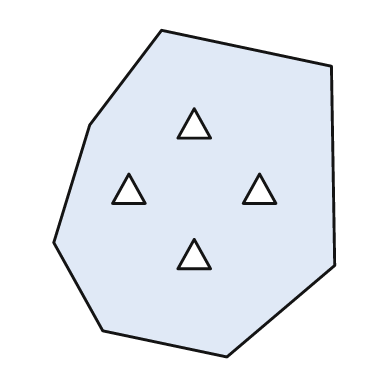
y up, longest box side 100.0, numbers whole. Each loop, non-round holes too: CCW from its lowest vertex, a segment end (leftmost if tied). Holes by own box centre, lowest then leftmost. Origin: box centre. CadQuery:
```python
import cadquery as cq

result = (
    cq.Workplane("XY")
    .moveTo(10.0, -50.0)
    .lineTo(43.0, -22.0)
    .lineTo(42.0, 39.0)
    .lineTo(-10.0, 50.0)
    .lineTo(-32.0, 21.0)
    .lineTo(-43.0, -15.0)
    .lineTo(-28.0, -42.0)
    .close()
    .moveTo(-5.0, -23.0)
    .lineTo(5.0, -23.0)
    .lineTo(0.0, -14.0)
    .close()
    .moveTo(-25.0, -3.0)
    .lineTo(-15.0, -3.0)
    .lineTo(-20.0, 6.0)
    .close()
    .moveTo(15.0, -3.0)
    .lineTo(25.0, -3.0)
    .lineTo(20.0, 6.0)
    .close()
    .moveTo(-5.0, 17.0)
    .lineTo(5.0, 17.0)
    .lineTo(0.0, 26.0)
    .close()
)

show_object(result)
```